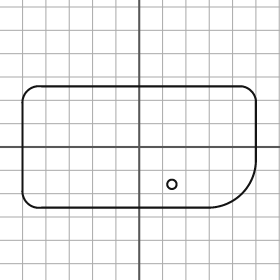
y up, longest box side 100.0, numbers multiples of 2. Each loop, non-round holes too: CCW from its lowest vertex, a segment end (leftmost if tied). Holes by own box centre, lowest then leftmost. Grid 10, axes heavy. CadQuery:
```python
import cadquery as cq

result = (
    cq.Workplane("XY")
    .moveTo(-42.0, -26.0)
    .lineTo(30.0, -26.0)
    .threePointArc((44.0, -20.0), (50.0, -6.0))
    .lineTo(50.0, 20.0)
    .threePointArc((48.0, 24.0), (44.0, 26.0))
    .lineTo(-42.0, 26.0)
    .threePointArc((-48.0, 24.0), (-50.0, 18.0))
    .lineTo(-50.0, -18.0)
    .threePointArc((-48.0, -24.0), (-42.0, -26.0))
    .close()
    .moveTo(14.0, -16.0)
    .circle(2.0)
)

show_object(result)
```